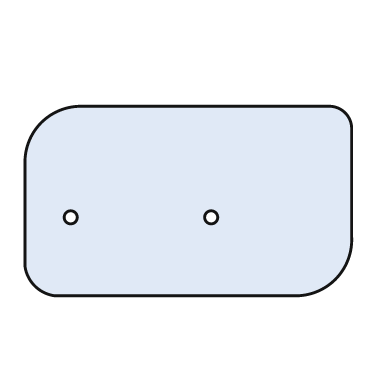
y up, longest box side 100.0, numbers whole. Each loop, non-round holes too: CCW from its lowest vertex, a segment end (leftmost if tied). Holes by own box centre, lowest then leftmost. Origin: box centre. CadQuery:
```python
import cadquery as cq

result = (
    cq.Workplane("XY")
    .moveTo(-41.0, -29.0)
    .lineTo(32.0, -29.0)
    .threePointArc((45.0, -24.0), (50.0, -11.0))
    .lineTo(50.0, 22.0)
    .threePointArc((48.0, 27.0), (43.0, 29.0))
    .lineTo(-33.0, 29.0)
    .threePointArc((-45.0, 24.0), (-50.0, 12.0))
    .lineTo(-50.0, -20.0)
    .threePointArc((-47.0, -26.0), (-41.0, -29.0))
    .close()
    .moveTo(-36.0, -5.0)
    .circle(2.0)
    .moveTo(7.0, -5.0)
    .circle(2.0)
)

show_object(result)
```